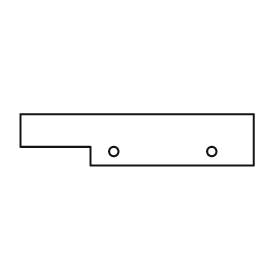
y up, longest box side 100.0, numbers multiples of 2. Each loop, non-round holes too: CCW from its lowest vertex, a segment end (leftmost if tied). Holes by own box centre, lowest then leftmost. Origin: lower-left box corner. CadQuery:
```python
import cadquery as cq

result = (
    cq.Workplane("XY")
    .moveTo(30.0, 0.0)
    .lineTo(100.0, 0.0)
    .lineTo(100.0, 22.0)
    .lineTo(0.0, 22.0)
    .lineTo(0.0, 8.0)
    .lineTo(30.0, 8.0)
    .close()
    .moveTo(40.0, 6.0)
    .circle(2.0)
    .moveTo(82.0, 6.0)
    .circle(2.0)
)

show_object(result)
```